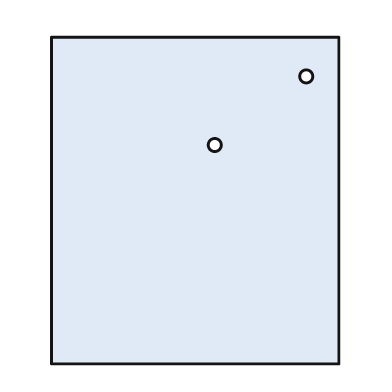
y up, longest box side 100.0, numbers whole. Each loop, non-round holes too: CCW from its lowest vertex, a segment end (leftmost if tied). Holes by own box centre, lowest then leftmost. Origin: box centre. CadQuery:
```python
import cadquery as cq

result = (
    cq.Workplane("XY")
    .moveTo(-44.0, -50.0)
    .lineTo(44.0, -50.0)
    .lineTo(44.0, 50.0)
    .lineTo(-44.0, 50.0)
    .close()
    .moveTo(6.0, 17.0)
    .circle(2.0)
    .moveTo(34.0, 38.0)
    .circle(2.0)
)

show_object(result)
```